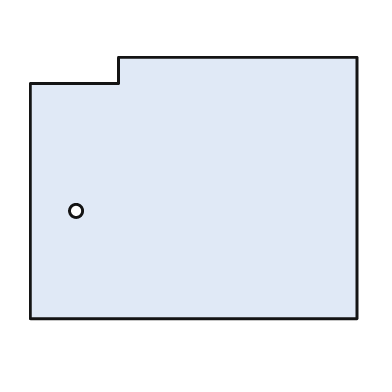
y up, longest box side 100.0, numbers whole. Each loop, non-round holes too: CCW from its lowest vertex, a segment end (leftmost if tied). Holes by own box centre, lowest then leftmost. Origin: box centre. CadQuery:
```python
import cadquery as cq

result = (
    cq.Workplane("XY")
    .moveTo(-50.0, -40.0)
    .lineTo(50.0, -40.0)
    .lineTo(50.0, 40.0)
    .lineTo(-23.0, 40.0)
    .lineTo(-23.0, 32.0)
    .lineTo(-50.0, 32.0)
    .close()
    .moveTo(-36.0, -7.0)
    .circle(2.0)
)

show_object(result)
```